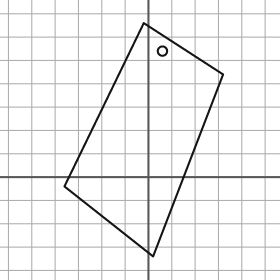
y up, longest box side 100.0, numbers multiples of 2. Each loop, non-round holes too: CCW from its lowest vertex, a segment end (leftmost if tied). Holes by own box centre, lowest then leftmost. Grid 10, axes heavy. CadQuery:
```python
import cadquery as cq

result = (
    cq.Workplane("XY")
    .moveTo(2.0, -34.0)
    .lineTo(32.0, 44.0)
    .lineTo(-2.0, 66.0)
    .lineTo(-36.0, -4.0)
    .close()
    .moveTo(6.0, 54.0)
    .circle(2.0)
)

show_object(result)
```